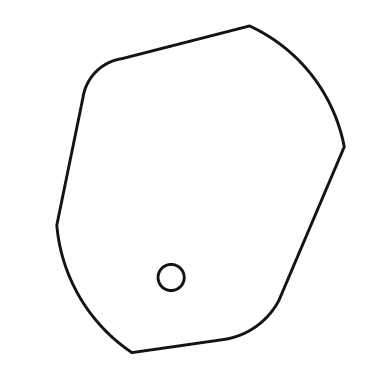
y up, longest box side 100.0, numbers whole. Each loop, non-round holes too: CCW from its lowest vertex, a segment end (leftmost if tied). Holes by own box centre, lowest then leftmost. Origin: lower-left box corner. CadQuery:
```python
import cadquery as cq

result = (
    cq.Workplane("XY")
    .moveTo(23.0, 0.0)
    .lineTo(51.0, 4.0)
    .threePointArc((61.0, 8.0), (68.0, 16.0))
    .lineTo(88.0, 63.0)
    .threePointArc((78.0, 85.0), (59.0, 100.0))
    .lineTo(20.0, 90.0)
    .threePointArc((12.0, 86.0), (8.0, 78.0))
    .lineTo(0.0, 39.0)
    .threePointArc((7.0, 17.0), (23.0, 0.0))
    .close()
    .moveTo(35.0, 23.0)
    .circle(4.0)
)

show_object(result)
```